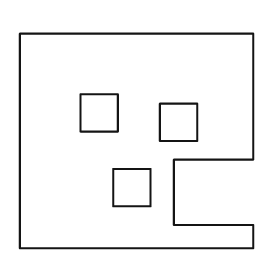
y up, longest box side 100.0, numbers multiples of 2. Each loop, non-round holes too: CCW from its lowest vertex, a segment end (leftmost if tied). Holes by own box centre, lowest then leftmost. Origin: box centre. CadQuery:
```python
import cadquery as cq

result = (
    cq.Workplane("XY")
    .moveTo(-50.0, -46.0)
    .lineTo(50.0, -46.0)
    .lineTo(50.0, -36.0)
    .lineTo(16.0, -36.0)
    .lineTo(16.0, -8.0)
    .lineTo(50.0, -8.0)
    .lineTo(50.0, 46.0)
    .lineTo(-50.0, 46.0)
    .close()
    .moveTo(-10.0, -28.0)
    .lineTo(6.0, -28.0)
    .lineTo(6.0, -12.0)
    .lineTo(-10.0, -12.0)
    .close()
    .moveTo(10.0, 0.0)
    .lineTo(26.0, 0.0)
    .lineTo(26.0, 16.0)
    .lineTo(10.0, 16.0)
    .close()
    .moveTo(-24.0, 4.0)
    .lineTo(-8.0, 4.0)
    .lineTo(-8.0, 20.0)
    .lineTo(-24.0, 20.0)
    .close()
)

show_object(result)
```